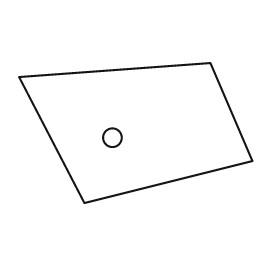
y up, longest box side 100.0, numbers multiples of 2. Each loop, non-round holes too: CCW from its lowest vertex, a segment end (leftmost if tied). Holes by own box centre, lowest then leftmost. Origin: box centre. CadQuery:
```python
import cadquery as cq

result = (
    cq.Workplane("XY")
    .moveTo(-22.0, -30.0)
    .lineTo(50.0, -12.0)
    .lineTo(32.0, 30.0)
    .lineTo(-50.0, 24.0)
    .close()
    .moveTo(-10.0, -2.0)
    .circle(4.0)
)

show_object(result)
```